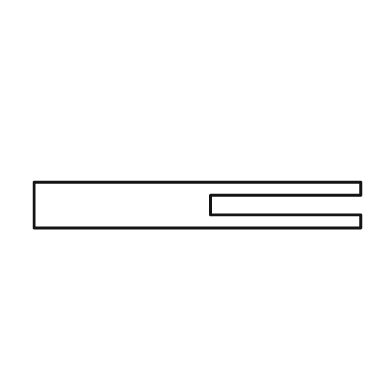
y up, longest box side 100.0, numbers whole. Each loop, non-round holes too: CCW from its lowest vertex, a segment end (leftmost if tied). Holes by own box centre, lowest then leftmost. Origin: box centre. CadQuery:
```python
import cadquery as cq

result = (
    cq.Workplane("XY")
    .moveTo(-50.0, -7.0)
    .lineTo(50.0, -7.0)
    .lineTo(50.0, -3.0)
    .lineTo(4.0, -3.0)
    .lineTo(4.0, 3.0)
    .lineTo(50.0, 3.0)
    .lineTo(50.0, 7.0)
    .lineTo(-50.0, 7.0)
    .close()
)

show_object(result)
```